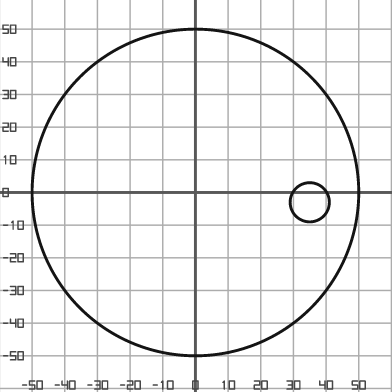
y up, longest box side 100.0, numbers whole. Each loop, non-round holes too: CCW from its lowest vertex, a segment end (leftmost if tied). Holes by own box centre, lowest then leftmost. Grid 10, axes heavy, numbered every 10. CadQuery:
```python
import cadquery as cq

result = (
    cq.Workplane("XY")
    .moveTo(0.0, 0.0)
    .circle(50.0)
    .moveTo(35.0, -3.0)
    .circle(6.0)
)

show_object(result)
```